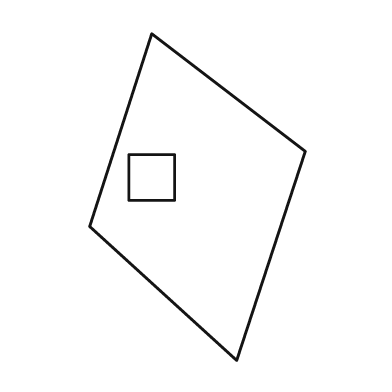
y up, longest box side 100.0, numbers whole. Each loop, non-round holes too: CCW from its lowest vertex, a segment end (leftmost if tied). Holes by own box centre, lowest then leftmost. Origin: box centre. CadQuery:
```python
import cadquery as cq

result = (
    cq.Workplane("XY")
    .moveTo(12.0, -50.0)
    .lineTo(33.0, 14.0)
    .lineTo(-14.0, 50.0)
    .lineTo(-33.0, -9.0)
    .close()
    .moveTo(-21.0, -1.0)
    .lineTo(-7.0, -1.0)
    .lineTo(-7.0, 13.0)
    .lineTo(-21.0, 13.0)
    .close()
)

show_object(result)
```